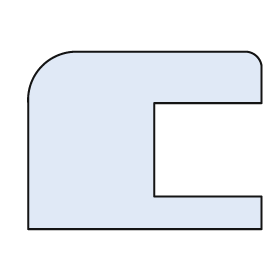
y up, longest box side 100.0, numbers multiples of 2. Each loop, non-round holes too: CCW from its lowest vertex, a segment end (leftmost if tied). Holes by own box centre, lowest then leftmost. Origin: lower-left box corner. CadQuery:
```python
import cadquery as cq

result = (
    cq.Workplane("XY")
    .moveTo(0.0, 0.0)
    .lineTo(100.0, 0.0)
    .lineTo(100.0, 14.0)
    .lineTo(54.0, 14.0)
    .lineTo(54.0, 54.0)
    .lineTo(100.0, 54.0)
    .lineTo(100.0, 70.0)
    .threePointArc((98.0, 74.0), (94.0, 76.0))
    .lineTo(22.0, 76.0)
    .threePointArc((6.0, 70.0), (0.0, 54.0))
    .close()
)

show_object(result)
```